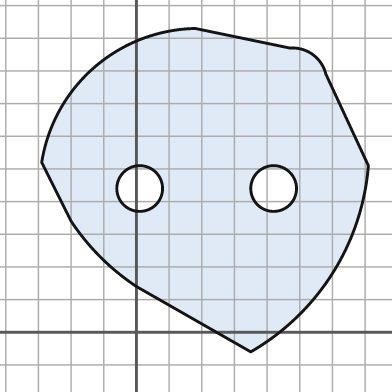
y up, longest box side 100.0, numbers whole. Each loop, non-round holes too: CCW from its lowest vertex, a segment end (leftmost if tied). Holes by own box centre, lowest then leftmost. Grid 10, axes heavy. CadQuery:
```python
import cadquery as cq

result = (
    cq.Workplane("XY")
    .moveTo(35.0, -6.0)
    .threePointArc((60.0, 18.0), (71.0, 51.0))
    .lineTo(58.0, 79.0)
    .threePointArc((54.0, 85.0), (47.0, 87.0))
    .lineTo(18.0, 93.0)
    .threePointArc((-13.0, 81.0), (-29.0, 52.0))
    .lineTo(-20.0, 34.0)
    .threePointArc((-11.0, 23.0), (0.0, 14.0))
    .close()
    .moveTo(1.0, 44.0)
    .circle(7.0)
    .moveTo(42.0, 44.0)
    .circle(7.0)
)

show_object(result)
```